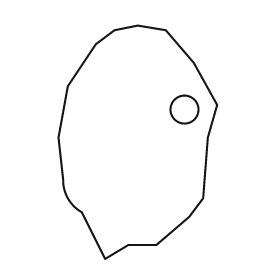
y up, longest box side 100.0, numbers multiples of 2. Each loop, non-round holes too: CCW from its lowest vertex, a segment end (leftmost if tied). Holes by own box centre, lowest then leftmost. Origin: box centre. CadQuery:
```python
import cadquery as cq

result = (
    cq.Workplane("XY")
    .moveTo(-14.0, -50.0)
    .lineTo(-4.0, -44.0)
    .lineTo(8.0, -44.0)
    .lineTo(22.0, -32.0)
    .lineTo(28.0, -24.0)
    .lineTo(30.0, 2.0)
    .lineTo(34.0, 16.0)
    .lineTo(24.0, 34.0)
    .lineTo(12.0, 48.0)
    .lineTo(0.0, 50.0)
    .lineTo(-10.0, 48.0)
    .lineTo(-18.0, 42.0)
    .lineTo(-30.0, 24.0)
    .lineTo(-34.0, 2.0)
    .lineTo(-32.0, -16.0)
    .threePointArc((-30.0, -24.0), (-24.0, -30.0))
    .close()
    .moveTo(20.0, 14.0)
    .circle(6.0)
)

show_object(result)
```